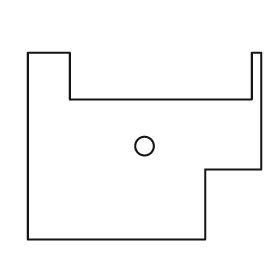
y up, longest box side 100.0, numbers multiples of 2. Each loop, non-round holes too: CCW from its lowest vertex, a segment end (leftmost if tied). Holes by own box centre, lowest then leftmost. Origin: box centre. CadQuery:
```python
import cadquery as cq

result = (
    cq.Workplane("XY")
    .moveTo(-50.0, -40.0)
    .lineTo(26.0, -40.0)
    .lineTo(26.0, -10.0)
    .lineTo(50.0, -10.0)
    .lineTo(50.0, 40.0)
    .lineTo(46.0, 40.0)
    .lineTo(46.0, 20.0)
    .lineTo(-32.0, 20.0)
    .lineTo(-32.0, 40.0)
    .lineTo(-50.0, 40.0)
    .close()
    .moveTo(0.0, 0.0)
    .circle(4.0)
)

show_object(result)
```